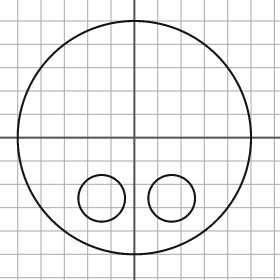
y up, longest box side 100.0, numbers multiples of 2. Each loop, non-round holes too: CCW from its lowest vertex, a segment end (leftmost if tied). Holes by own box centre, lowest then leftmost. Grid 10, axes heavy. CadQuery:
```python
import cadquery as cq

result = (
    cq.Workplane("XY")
    .moveTo(0.0, 0.0)
    .circle(50.0)
    .moveTo(-14.0, -26.0)
    .circle(10.0)
    .moveTo(16.0, -26.0)
    .circle(10.0)
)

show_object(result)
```